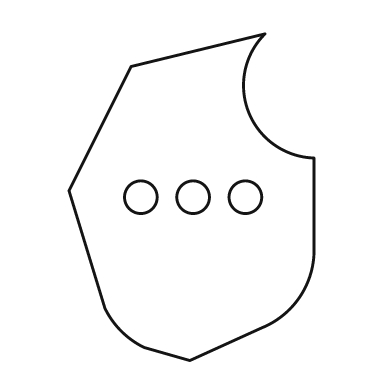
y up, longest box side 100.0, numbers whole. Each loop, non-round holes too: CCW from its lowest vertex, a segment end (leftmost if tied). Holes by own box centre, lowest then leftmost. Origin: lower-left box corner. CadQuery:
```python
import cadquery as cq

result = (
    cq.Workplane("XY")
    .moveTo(37.0, 0.0)
    .lineTo(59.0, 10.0)
    .threePointArc((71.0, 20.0), (75.0, 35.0))
    .lineTo(75.0, 62.0)
    .threePointArc((55.0, 76.0), (60.0, 100.0))
    .lineTo(19.0, 90.0)
    .lineTo(0.0, 52.0)
    .lineTo(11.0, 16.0)
    .threePointArc((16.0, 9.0), (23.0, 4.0))
    .close()
    .moveTo(22.0, 50.0)
    .circle(5.0)
    .moveTo(38.0, 50.0)
    .circle(5.0)
    .moveTo(54.0, 50.0)
    .circle(5.0)
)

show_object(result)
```